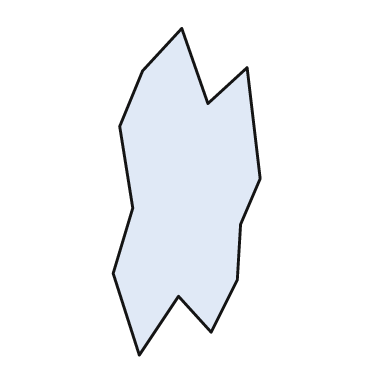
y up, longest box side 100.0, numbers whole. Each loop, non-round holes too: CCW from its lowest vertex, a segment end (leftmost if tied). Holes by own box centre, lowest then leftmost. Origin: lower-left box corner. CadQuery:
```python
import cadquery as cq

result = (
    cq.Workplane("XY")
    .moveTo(8.0, 0.0)
    .lineTo(20.0, 18.0)
    .lineTo(30.0, 7.0)
    .lineTo(38.0, 23.0)
    .lineTo(39.0, 40.0)
    .lineTo(45.0, 54.0)
    .lineTo(41.0, 88.0)
    .lineTo(29.0, 77.0)
    .lineTo(21.0, 100.0)
    .lineTo(9.0, 87.0)
    .lineTo(2.0, 70.0)
    .lineTo(6.0, 45.0)
    .lineTo(0.0, 25.0)
    .close()
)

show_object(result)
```